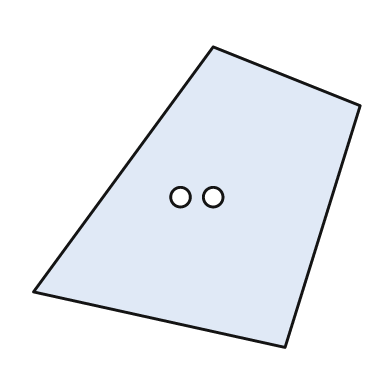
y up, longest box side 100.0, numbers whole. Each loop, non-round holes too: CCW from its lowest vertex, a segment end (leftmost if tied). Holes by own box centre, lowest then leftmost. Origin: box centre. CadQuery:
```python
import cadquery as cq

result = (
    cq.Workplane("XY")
    .moveTo(27.0, -46.0)
    .lineTo(50.0, 28.0)
    .lineTo(5.0, 46.0)
    .lineTo(-50.0, -29.0)
    .close()
    .moveTo(-5.0, 0.0)
    .circle(3.0)
    .moveTo(5.0, 0.0)
    .circle(3.0)
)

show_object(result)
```